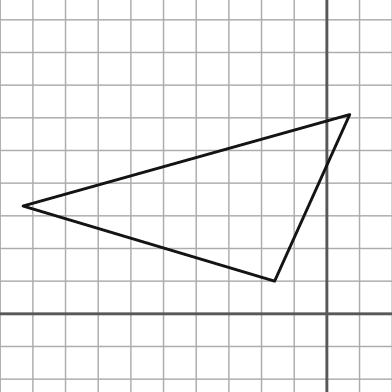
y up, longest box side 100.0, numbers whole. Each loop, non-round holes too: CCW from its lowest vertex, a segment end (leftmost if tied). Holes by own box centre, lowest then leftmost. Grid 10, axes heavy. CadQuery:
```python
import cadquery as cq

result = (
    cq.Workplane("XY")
    .moveTo(-16.0, 10.0)
    .lineTo(7.0, 61.0)
    .lineTo(-93.0, 33.0)
    .close()
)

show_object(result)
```